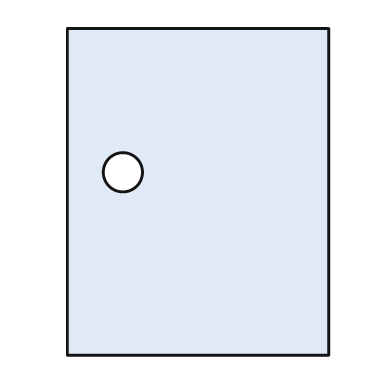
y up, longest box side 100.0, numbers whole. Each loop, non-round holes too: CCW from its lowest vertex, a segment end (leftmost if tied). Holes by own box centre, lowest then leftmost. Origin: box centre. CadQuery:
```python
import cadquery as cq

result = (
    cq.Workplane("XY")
    .moveTo(-40.0, -50.0)
    .lineTo(40.0, -50.0)
    .lineTo(40.0, 50.0)
    .lineTo(-40.0, 50.0)
    .close()
    .moveTo(-23.0, 6.0)
    .circle(6.0)
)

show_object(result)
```